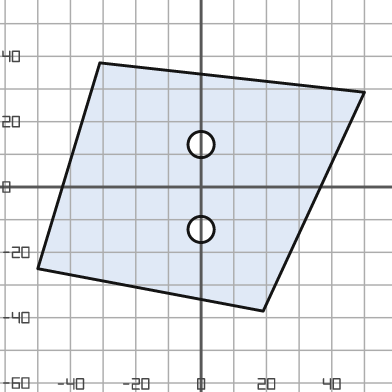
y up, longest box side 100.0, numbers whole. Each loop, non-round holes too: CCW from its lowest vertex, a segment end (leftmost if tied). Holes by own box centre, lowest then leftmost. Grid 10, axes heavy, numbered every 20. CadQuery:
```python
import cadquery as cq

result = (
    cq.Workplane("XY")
    .moveTo(19.0, -38.0)
    .lineTo(50.0, 29.0)
    .lineTo(-31.0, 38.0)
    .lineTo(-50.0, -25.0)
    .close()
    .moveTo(0.0, -13.0)
    .circle(4.0)
    .moveTo(0.0, 13.0)
    .circle(4.0)
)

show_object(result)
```